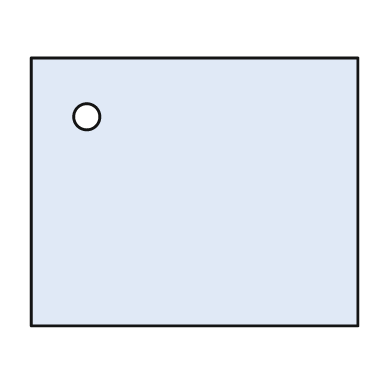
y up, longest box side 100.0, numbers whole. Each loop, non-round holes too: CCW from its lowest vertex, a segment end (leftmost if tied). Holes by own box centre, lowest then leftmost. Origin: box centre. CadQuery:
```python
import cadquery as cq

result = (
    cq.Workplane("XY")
    .moveTo(-50.0, -41.0)
    .lineTo(50.0, -41.0)
    .lineTo(50.0, 41.0)
    .lineTo(-50.0, 41.0)
    .close()
    .moveTo(-33.0, 23.0)
    .circle(4.0)
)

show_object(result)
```